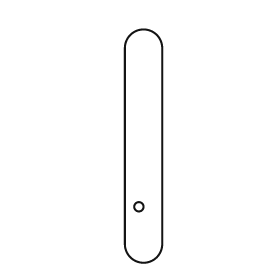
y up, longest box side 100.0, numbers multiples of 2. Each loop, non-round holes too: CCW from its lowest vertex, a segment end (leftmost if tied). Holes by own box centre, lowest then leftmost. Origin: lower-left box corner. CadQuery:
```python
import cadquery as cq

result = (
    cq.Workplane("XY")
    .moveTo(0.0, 8.0)
    .threePointArc((8.0, 0.0), (16.0, 8.0))
    .lineTo(16.0, 92.0)
    .threePointArc((8.0, 100.0), (0.0, 92.0))
    .close()
    .moveTo(6.0, 24.0)
    .circle(2.0)
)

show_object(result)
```